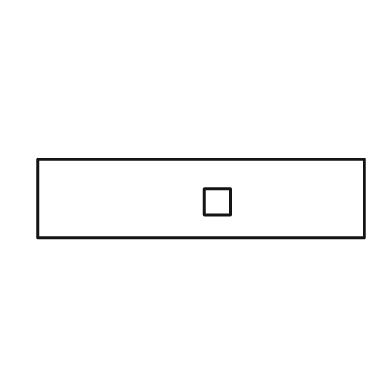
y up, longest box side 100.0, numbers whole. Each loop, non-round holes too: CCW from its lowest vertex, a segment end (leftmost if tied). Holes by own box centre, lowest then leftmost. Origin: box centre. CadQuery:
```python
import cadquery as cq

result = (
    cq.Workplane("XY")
    .moveTo(-50.0, -12.0)
    .lineTo(50.0, -12.0)
    .lineTo(50.0, 12.0)
    .lineTo(-50.0, 12.0)
    .close()
    .moveTo(1.0, -5.0)
    .lineTo(9.0, -5.0)
    .lineTo(9.0, 3.0)
    .lineTo(1.0, 3.0)
    .close()
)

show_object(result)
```